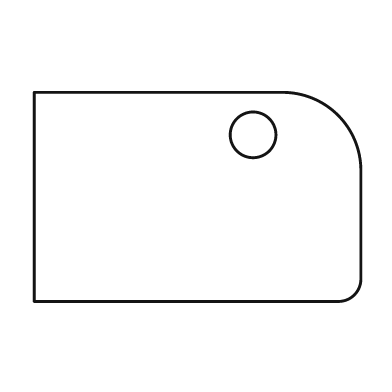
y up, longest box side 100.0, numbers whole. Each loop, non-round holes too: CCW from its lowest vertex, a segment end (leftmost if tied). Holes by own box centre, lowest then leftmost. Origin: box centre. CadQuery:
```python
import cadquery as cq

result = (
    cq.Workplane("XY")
    .moveTo(-50.0, -32.0)
    .lineTo(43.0, -32.0)
    .threePointArc((48.0, -30.0), (50.0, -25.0))
    .lineTo(50.0, 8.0)
    .threePointArc((43.0, 25.0), (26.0, 32.0))
    .lineTo(-50.0, 32.0)
    .close()
    .moveTo(17.0, 19.0)
    .circle(7.0)
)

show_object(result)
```